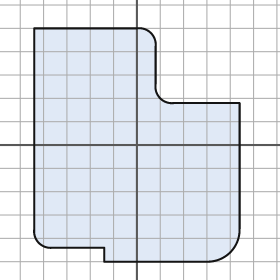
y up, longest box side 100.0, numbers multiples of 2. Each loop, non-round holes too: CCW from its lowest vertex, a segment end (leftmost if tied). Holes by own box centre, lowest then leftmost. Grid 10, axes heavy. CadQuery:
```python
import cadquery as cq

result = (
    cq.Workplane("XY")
    .moveTo(-14.0, -50.0)
    .lineTo(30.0, -50.0)
    .threePointArc((40.0, -46.0), (44.0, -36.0))
    .lineTo(44.0, 18.0)
    .lineTo(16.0, 18.0)
    .threePointArc((10.0, 20.0), (8.0, 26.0))
    .lineTo(8.0, 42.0)
    .threePointArc((6.0, 48.0), (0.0, 50.0))
    .lineTo(-44.0, 50.0)
    .lineTo(-44.0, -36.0)
    .threePointArc((-42.0, -42.0), (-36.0, -44.0))
    .lineTo(-14.0, -44.0)
    .close()
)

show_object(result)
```